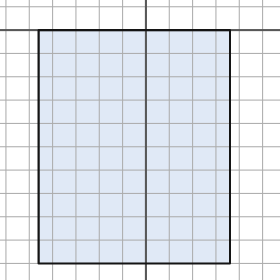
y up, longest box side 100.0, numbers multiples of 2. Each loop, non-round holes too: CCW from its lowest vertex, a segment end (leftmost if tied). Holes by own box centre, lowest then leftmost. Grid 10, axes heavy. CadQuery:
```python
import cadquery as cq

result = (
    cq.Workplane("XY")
    .moveTo(-46.0, -100.0)
    .lineTo(36.0, -100.0)
    .lineTo(36.0, 0.0)
    .lineTo(-46.0, 0.0)
    .close()
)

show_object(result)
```